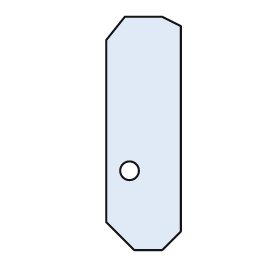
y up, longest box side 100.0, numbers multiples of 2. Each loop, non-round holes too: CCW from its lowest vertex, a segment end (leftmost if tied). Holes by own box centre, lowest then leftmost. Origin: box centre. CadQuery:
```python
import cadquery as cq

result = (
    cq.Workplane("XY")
    .moveTo(-4.0, -50.0)
    .lineTo(8.0, -50.0)
    .lineTo(16.0, -42.0)
    .lineTo(16.0, 46.0)
    .lineTo(8.0, 50.0)
    .lineTo(-8.0, 50.0)
    .lineTo(-16.0, 40.0)
    .lineTo(-16.0, -38.0)
    .close()
    .moveTo(-6.0, -16.0)
    .circle(4.0)
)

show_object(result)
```